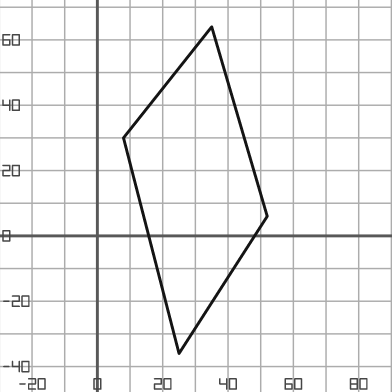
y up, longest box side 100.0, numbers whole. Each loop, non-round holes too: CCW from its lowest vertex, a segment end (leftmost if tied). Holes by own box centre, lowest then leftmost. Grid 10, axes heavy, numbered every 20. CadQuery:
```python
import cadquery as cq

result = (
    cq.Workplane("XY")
    .moveTo(25.0, -36.0)
    .lineTo(52.0, 6.0)
    .lineTo(35.0, 64.0)
    .lineTo(8.0, 30.0)
    .close()
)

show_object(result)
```